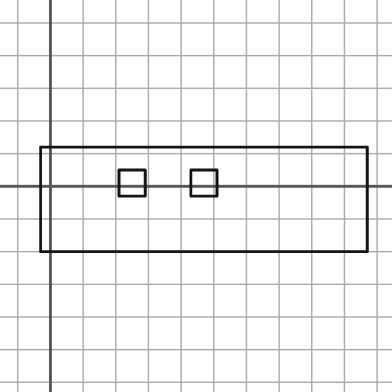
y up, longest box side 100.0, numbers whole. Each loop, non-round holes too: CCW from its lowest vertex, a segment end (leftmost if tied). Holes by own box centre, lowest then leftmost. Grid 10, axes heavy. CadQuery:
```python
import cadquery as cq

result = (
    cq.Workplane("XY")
    .moveTo(-3.0, -20.0)
    .lineTo(97.0, -20.0)
    .lineTo(97.0, 12.0)
    .lineTo(-3.0, 12.0)
    .close()
    .moveTo(21.0, -3.0)
    .lineTo(29.0, -3.0)
    .lineTo(29.0, 5.0)
    .lineTo(21.0, 5.0)
    .close()
    .moveTo(43.0, -3.0)
    .lineTo(51.0, -3.0)
    .lineTo(51.0, 5.0)
    .lineTo(43.0, 5.0)
    .close()
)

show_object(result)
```